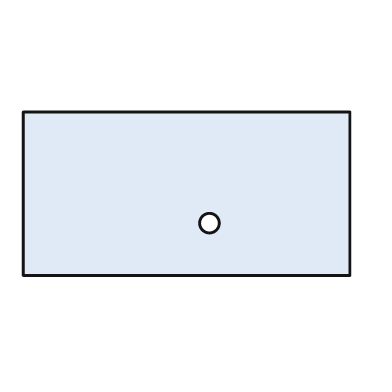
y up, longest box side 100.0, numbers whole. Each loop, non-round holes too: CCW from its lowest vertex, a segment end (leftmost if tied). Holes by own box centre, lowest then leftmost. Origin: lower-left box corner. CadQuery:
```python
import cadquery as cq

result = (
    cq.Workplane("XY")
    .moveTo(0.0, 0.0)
    .lineTo(100.0, 0.0)
    .lineTo(100.0, 50.0)
    .lineTo(0.0, 50.0)
    .close()
    .moveTo(57.0, 16.0)
    .circle(3.0)
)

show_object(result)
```